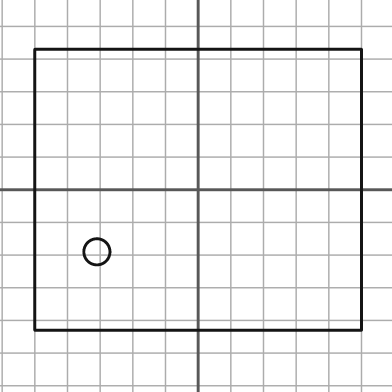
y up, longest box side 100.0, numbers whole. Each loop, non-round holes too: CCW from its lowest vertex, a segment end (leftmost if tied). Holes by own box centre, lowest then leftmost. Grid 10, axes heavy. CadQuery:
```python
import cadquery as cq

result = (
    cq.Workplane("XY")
    .moveTo(-50.0, -43.0)
    .lineTo(50.0, -43.0)
    .lineTo(50.0, 43.0)
    .lineTo(-50.0, 43.0)
    .close()
    .moveTo(-31.0, -19.0)
    .circle(4.0)
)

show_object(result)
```